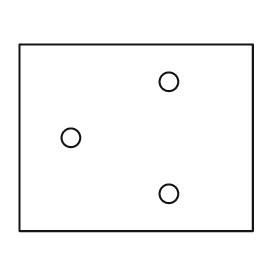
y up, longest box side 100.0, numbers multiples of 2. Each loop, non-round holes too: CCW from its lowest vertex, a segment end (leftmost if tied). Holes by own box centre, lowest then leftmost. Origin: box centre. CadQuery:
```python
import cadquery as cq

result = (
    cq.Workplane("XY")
    .moveTo(-50.0, -40.0)
    .lineTo(50.0, -40.0)
    .lineTo(50.0, 40.0)
    .lineTo(-50.0, 40.0)
    .close()
    .moveTo(14.0, -24.0)
    .circle(4.0)
    .moveTo(-28.0, 0.0)
    .circle(4.0)
    .moveTo(14.0, 24.0)
    .circle(4.0)
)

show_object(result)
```